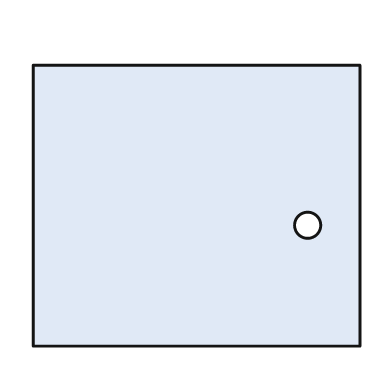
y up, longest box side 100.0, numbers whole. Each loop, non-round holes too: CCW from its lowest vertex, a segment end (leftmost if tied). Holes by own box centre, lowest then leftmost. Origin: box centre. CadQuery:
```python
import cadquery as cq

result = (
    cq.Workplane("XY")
    .moveTo(-50.0, -43.0)
    .lineTo(50.0, -43.0)
    .lineTo(50.0, 43.0)
    .lineTo(-50.0, 43.0)
    .close()
    .moveTo(34.0, -6.0)
    .circle(4.0)
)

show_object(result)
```